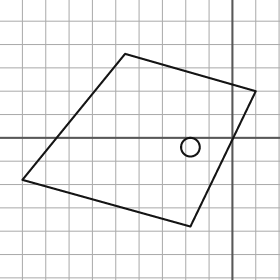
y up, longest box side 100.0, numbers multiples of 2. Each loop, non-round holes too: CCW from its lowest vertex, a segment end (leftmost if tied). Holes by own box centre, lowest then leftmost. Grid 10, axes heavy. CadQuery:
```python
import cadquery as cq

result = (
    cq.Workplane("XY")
    .moveTo(-18.0, -38.0)
    .lineTo(10.0, 20.0)
    .lineTo(-46.0, 36.0)
    .lineTo(-90.0, -18.0)
    .close()
    .moveTo(-18.0, -4.0)
    .circle(4.0)
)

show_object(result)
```